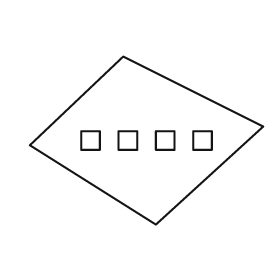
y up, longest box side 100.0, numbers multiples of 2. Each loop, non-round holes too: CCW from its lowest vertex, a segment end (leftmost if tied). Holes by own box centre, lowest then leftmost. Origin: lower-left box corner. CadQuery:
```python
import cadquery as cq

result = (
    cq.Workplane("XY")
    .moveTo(54.0, 0.0)
    .lineTo(100.0, 42.0)
    .lineTo(40.0, 72.0)
    .lineTo(0.0, 34.0)
    .close()
    .moveTo(22.0, 32.0)
    .lineTo(30.0, 32.0)
    .lineTo(30.0, 40.0)
    .lineTo(22.0, 40.0)
    .close()
    .moveTo(38.0, 32.0)
    .lineTo(46.0, 32.0)
    .lineTo(46.0, 40.0)
    .lineTo(38.0, 40.0)
    .close()
    .moveTo(54.0, 32.0)
    .lineTo(62.0, 32.0)
    .lineTo(62.0, 40.0)
    .lineTo(54.0, 40.0)
    .close()
    .moveTo(70.0, 32.0)
    .lineTo(78.0, 32.0)
    .lineTo(78.0, 40.0)
    .lineTo(70.0, 40.0)
    .close()
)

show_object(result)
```